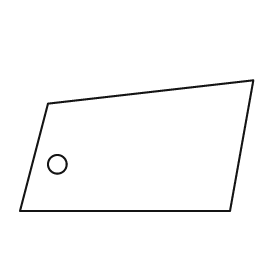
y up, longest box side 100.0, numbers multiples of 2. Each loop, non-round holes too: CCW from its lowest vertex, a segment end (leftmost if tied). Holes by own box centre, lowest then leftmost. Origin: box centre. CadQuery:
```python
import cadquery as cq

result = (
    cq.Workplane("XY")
    .moveTo(-50.0, -28.0)
    .lineTo(40.0, -28.0)
    .lineTo(50.0, 28.0)
    .lineTo(-38.0, 18.0)
    .close()
    .moveTo(-34.0, -8.0)
    .circle(4.0)
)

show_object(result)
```